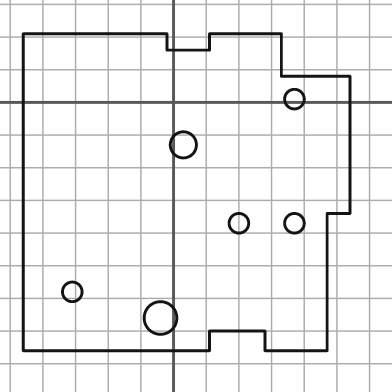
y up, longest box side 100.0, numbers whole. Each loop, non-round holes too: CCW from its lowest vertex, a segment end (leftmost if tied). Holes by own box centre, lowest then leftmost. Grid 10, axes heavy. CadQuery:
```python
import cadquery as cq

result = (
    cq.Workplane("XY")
    .moveTo(-46.0, -76.0)
    .lineTo(11.0, -76.0)
    .lineTo(11.0, -70.0)
    .lineTo(28.0, -70.0)
    .lineTo(28.0, -76.0)
    .lineTo(47.0, -76.0)
    .lineTo(47.0, -34.0)
    .lineTo(54.0, -34.0)
    .lineTo(54.0, 8.0)
    .lineTo(33.0, 8.0)
    .lineTo(33.0, 21.0)
    .lineTo(11.0, 21.0)
    .lineTo(11.0, 16.0)
    .lineTo(-2.0, 16.0)
    .lineTo(-2.0, 21.0)
    .lineTo(-46.0, 21.0)
    .close()
    .moveTo(-4.0, -66.0)
    .circle(5.0)
    .moveTo(-31.0, -58.0)
    .circle(3.0)
    .moveTo(20.0, -37.0)
    .circle(3.0)
    .moveTo(37.0, -37.0)
    .circle(3.0)
    .moveTo(3.0, -13.0)
    .circle(4.0)
    .moveTo(37.0, 1.0)
    .circle(3.0)
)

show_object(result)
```